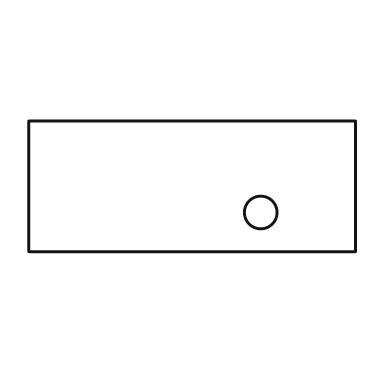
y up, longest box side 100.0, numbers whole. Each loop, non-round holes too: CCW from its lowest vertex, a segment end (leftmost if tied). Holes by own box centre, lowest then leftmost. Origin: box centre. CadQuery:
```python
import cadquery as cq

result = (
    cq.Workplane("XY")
    .moveTo(-50.0, -20.0)
    .lineTo(50.0, -20.0)
    .lineTo(50.0, 20.0)
    .lineTo(-50.0, 20.0)
    .close()
    .moveTo(21.0, -8.0)
    .circle(5.0)
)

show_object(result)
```